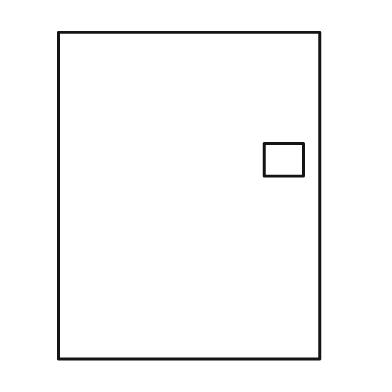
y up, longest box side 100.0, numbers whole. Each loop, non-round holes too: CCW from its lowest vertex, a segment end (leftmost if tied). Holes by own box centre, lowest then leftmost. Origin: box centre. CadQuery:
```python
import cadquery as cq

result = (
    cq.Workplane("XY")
    .moveTo(-40.0, -50.0)
    .lineTo(40.0, -50.0)
    .lineTo(40.0, 50.0)
    .lineTo(-40.0, 50.0)
    .close()
    .moveTo(23.0, 6.0)
    .lineTo(35.0, 6.0)
    .lineTo(35.0, 16.0)
    .lineTo(23.0, 16.0)
    .close()
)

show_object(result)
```